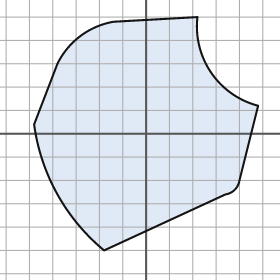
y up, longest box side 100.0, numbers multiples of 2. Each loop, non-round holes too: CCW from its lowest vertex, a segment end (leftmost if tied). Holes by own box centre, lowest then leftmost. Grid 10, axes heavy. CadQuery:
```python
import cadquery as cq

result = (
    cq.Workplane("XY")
    .moveTo(-18.0, -50.0)
    .lineTo(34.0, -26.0)
    .threePointArc((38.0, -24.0), (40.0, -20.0))
    .lineTo(48.0, 12.0)
    .threePointArc((28.0, 26.0), (22.0, 50.0))
    .lineTo(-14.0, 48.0)
    .threePointArc((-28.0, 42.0), (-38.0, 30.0))
    .lineTo(-48.0, 4.0)
    .threePointArc((-38.0, -26.0), (-18.0, -50.0))
    .close()
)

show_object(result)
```